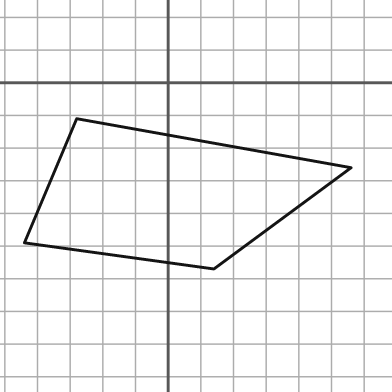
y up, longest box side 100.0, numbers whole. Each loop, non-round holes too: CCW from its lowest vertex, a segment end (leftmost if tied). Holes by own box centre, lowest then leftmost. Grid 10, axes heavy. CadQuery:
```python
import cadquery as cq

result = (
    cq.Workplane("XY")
    .moveTo(14.0, -57.0)
    .lineTo(56.0, -26.0)
    .lineTo(-28.0, -11.0)
    .lineTo(-44.0, -49.0)
    .close()
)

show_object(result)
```